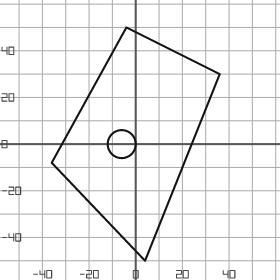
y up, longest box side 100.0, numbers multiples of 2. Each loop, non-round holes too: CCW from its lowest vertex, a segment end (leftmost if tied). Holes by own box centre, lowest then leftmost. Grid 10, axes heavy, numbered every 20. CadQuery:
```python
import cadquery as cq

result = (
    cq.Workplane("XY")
    .moveTo(4.0, -50.0)
    .lineTo(36.0, 30.0)
    .lineTo(-4.0, 50.0)
    .lineTo(-36.0, -8.0)
    .close()
    .moveTo(-6.0, 0.0)
    .circle(6.0)
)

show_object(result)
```